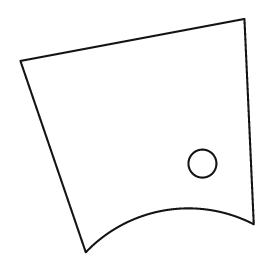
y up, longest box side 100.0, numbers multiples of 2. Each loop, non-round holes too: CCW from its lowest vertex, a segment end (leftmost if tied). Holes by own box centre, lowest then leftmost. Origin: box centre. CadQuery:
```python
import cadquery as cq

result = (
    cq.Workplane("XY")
    .moveTo(-22.0, -50.0)
    .threePointArc((12.0, -32.0), (50.0, -38.0))
    .lineTo(46.0, 50.0)
    .lineTo(-50.0, 32.0)
    .close()
    .moveTo(28.0, -12.0)
    .circle(6.0)
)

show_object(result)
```